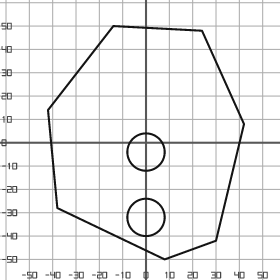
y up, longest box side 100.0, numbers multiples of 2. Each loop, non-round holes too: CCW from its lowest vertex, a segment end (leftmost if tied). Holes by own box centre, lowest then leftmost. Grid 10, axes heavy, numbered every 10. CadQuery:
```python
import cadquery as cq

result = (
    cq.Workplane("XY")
    .moveTo(8.0, -50.0)
    .lineTo(30.0, -42.0)
    .lineTo(42.0, 8.0)
    .lineTo(24.0, 48.0)
    .lineTo(-14.0, 50.0)
    .lineTo(-42.0, 14.0)
    .lineTo(-38.0, -28.0)
    .close()
    .moveTo(0.0, -32.0)
    .circle(8.0)
    .moveTo(0.0, -4.0)
    .circle(8.0)
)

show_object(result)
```